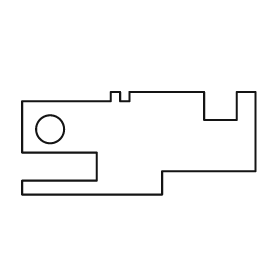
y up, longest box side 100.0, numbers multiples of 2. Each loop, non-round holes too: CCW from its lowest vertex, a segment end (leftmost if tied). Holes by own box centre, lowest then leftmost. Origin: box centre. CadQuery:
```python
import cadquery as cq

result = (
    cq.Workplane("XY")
    .moveTo(-50.0, -22.0)
    .lineTo(10.0, -22.0)
    .lineTo(10.0, -12.0)
    .lineTo(50.0, -12.0)
    .lineTo(50.0, 22.0)
    .lineTo(42.0, 22.0)
    .lineTo(42.0, 10.0)
    .lineTo(28.0, 10.0)
    .lineTo(28.0, 22.0)
    .lineTo(-4.0, 22.0)
    .lineTo(-4.0, 18.0)
    .lineTo(-8.0, 18.0)
    .lineTo(-8.0, 22.0)
    .lineTo(-12.0, 22.0)
    .lineTo(-12.0, 18.0)
    .lineTo(-50.0, 18.0)
    .lineTo(-50.0, -4.0)
    .lineTo(-18.0, -4.0)
    .lineTo(-18.0, -16.0)
    .lineTo(-50.0, -16.0)
    .close()
    .moveTo(-38.0, 6.0)
    .circle(6.0)
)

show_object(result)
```